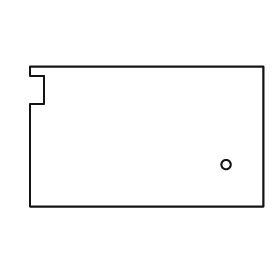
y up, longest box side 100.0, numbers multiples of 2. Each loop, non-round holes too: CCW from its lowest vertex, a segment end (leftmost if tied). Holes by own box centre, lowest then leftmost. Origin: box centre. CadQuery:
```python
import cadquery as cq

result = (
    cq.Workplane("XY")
    .moveTo(-50.0, -30.0)
    .lineTo(50.0, -30.0)
    .lineTo(50.0, 30.0)
    .lineTo(-50.0, 30.0)
    .lineTo(-50.0, 26.0)
    .lineTo(-44.0, 26.0)
    .lineTo(-44.0, 14.0)
    .lineTo(-50.0, 14.0)
    .close()
    .moveTo(34.0, -12.0)
    .circle(2.0)
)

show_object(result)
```